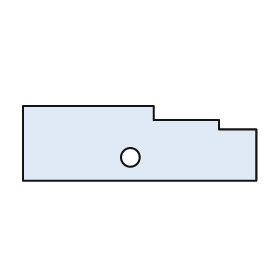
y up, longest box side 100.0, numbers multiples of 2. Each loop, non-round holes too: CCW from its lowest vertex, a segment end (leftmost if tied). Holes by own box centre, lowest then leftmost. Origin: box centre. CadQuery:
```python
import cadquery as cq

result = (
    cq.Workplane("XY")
    .moveTo(-50.0, -16.0)
    .lineTo(50.0, -16.0)
    .lineTo(50.0, 6.0)
    .lineTo(34.0, 6.0)
    .lineTo(34.0, 10.0)
    .lineTo(6.0, 10.0)
    .lineTo(6.0, 16.0)
    .lineTo(-50.0, 16.0)
    .close()
    .moveTo(-4.0, -6.0)
    .circle(4.0)
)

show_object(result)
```